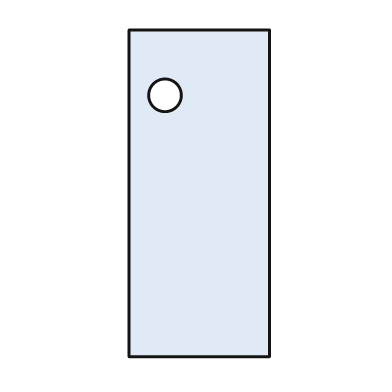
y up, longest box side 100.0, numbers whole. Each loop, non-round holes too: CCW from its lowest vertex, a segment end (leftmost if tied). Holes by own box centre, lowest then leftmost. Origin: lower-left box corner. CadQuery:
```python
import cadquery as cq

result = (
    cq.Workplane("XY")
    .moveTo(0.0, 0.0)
    .lineTo(43.0, 0.0)
    .lineTo(43.0, 100.0)
    .lineTo(0.0, 100.0)
    .close()
    .moveTo(11.0, 80.0)
    .circle(5.0)
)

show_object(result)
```